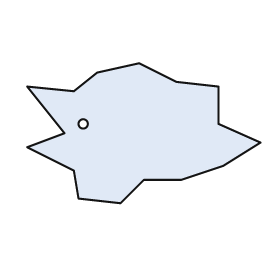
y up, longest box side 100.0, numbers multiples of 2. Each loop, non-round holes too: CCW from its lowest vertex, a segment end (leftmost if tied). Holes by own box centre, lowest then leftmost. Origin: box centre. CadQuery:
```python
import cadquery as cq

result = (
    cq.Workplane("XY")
    .moveTo(-10.0, -30.0)
    .lineTo(0.0, -20.0)
    .lineTo(16.0, -20.0)
    .lineTo(34.0, -14.0)
    .lineTo(50.0, -4.0)
    .lineTo(32.0, 4.0)
    .lineTo(32.0, 20.0)
    .lineTo(14.0, 22.0)
    .lineTo(-2.0, 30.0)
    .lineTo(-20.0, 26.0)
    .lineTo(-30.0, 18.0)
    .lineTo(-50.0, 20.0)
    .lineTo(-34.0, 0.0)
    .lineTo(-50.0, -6.0)
    .lineTo(-30.0, -16.0)
    .lineTo(-28.0, -28.0)
    .close()
    .moveTo(-26.0, 4.0)
    .circle(2.0)
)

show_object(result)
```